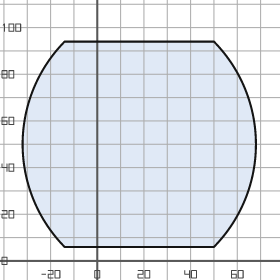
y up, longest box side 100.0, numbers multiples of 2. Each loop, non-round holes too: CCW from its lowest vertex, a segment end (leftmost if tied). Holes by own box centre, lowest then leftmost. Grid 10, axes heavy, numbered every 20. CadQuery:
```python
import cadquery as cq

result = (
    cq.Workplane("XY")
    .moveTo(-14.0, 6.0)
    .lineTo(50.0, 6.0)
    .threePointArc((68.0, 50.0), (50.0, 94.0))
    .lineTo(-14.0, 94.0)
    .threePointArc((-32.0, 50.0), (-14.0, 6.0))
    .close()
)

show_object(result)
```